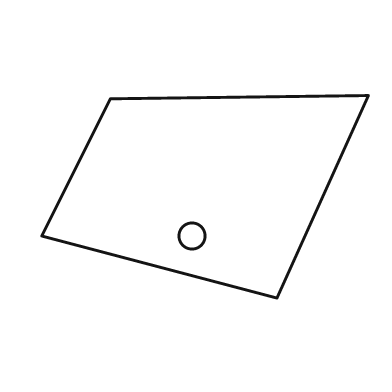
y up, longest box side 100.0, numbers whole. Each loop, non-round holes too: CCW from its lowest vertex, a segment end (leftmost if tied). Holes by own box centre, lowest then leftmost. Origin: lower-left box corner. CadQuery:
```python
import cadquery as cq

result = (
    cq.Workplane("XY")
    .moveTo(72.0, 0.0)
    .lineTo(100.0, 62.0)
    .lineTo(21.0, 61.0)
    .lineTo(0.0, 19.0)
    .close()
    .moveTo(46.0, 19.0)
    .circle(4.0)
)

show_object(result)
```